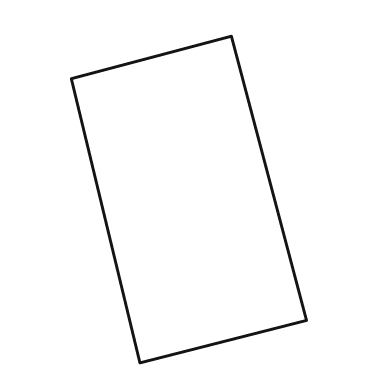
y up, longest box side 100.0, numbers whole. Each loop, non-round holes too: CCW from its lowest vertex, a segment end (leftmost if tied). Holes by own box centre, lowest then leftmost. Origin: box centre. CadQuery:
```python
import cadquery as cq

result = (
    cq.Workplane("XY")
    .moveTo(-15.0, -50.0)
    .lineTo(36.0, -37.0)
    .lineTo(13.0, 50.0)
    .lineTo(-36.0, 37.0)
    .close()
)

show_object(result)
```